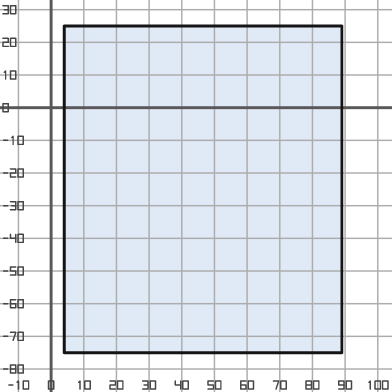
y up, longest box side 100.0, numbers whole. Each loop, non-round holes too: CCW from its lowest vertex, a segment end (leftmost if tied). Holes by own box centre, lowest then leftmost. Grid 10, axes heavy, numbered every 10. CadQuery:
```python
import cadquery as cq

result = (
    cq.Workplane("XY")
    .moveTo(4.0, -75.0)
    .lineTo(89.0, -75.0)
    .lineTo(89.0, 25.0)
    .lineTo(4.0, 25.0)
    .close()
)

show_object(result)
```